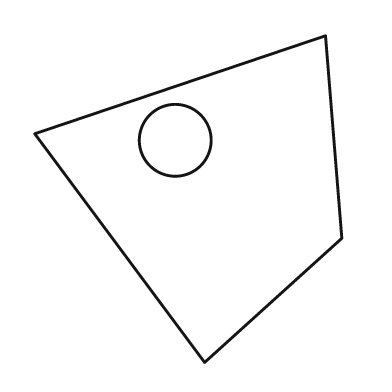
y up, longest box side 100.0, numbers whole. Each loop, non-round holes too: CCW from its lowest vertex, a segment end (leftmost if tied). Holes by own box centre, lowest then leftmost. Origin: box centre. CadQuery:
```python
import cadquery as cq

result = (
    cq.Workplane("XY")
    .moveTo(5.0, -50.0)
    .lineTo(47.0, -12.0)
    .lineTo(42.0, 50.0)
    .lineTo(-47.0, 20.0)
    .close()
    .moveTo(-4.0, 18.0)
    .circle(11.0)
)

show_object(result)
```